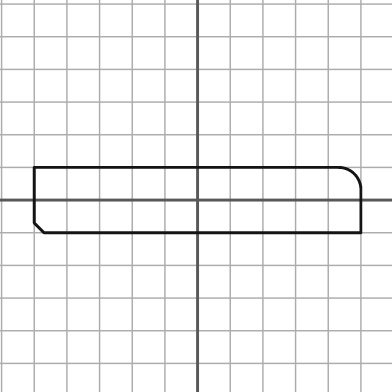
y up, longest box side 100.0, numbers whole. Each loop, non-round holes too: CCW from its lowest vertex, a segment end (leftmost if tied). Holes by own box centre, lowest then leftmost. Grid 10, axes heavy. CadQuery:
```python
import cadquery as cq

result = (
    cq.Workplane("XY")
    .moveTo(-47.0, -10.0)
    .lineTo(50.0, -10.0)
    .lineTo(50.0, 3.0)
    .threePointArc((48.0, 8.0), (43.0, 10.0))
    .lineTo(-50.0, 10.0)
    .lineTo(-50.0, -7.0)
    .close()
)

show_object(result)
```